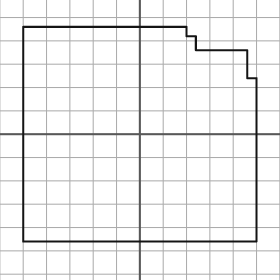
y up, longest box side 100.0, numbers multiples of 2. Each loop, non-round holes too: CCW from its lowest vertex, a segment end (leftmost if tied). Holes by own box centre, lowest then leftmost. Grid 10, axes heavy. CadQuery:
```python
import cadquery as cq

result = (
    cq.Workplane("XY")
    .moveTo(-50.0, -46.0)
    .lineTo(50.0, -46.0)
    .lineTo(50.0, 24.0)
    .lineTo(46.0, 24.0)
    .lineTo(46.0, 36.0)
    .lineTo(24.0, 36.0)
    .lineTo(24.0, 42.0)
    .lineTo(20.0, 42.0)
    .lineTo(20.0, 46.0)
    .lineTo(-50.0, 46.0)
    .close()
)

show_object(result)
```